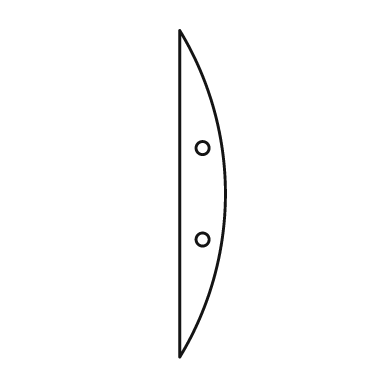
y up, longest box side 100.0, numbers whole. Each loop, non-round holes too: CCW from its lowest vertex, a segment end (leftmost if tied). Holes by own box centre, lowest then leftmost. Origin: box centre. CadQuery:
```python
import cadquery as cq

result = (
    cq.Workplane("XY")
    .moveTo(-7.0, -50.0)
    .threePointArc((7.0, 0.0), (-7.0, 50.0))
    .close()
    .moveTo(0.0, -14.0)
    .circle(2.0)
    .moveTo(0.0, 14.0)
    .circle(2.0)
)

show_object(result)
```